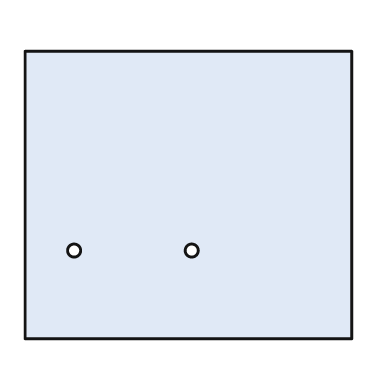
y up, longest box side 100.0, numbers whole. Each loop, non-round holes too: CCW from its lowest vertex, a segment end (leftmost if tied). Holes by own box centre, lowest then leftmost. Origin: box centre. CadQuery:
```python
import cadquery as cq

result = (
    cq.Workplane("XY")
    .moveTo(-50.0, -44.0)
    .lineTo(50.0, -44.0)
    .lineTo(50.0, 44.0)
    .lineTo(-50.0, 44.0)
    .close()
    .moveTo(-35.0, -17.0)
    .circle(2.0)
    .moveTo(1.0, -17.0)
    .circle(2.0)
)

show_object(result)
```